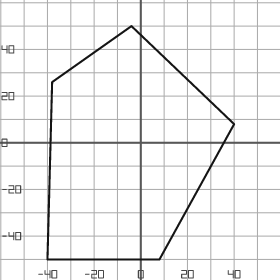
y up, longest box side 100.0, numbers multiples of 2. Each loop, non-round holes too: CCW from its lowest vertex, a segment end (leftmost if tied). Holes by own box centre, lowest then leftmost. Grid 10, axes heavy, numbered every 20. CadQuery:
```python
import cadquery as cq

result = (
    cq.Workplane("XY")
    .moveTo(-40.0, -50.0)
    .lineTo(8.0, -50.0)
    .lineTo(40.0, 8.0)
    .lineTo(-4.0, 50.0)
    .lineTo(-38.0, 26.0)
    .close()
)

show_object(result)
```